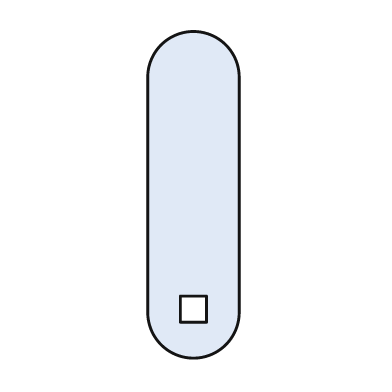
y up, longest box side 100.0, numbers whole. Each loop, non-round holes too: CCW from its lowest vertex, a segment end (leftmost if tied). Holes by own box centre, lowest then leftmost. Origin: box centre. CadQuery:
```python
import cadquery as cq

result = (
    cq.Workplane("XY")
    .moveTo(-14.0, -36.0)
    .threePointArc((0.0, -50.0), (14.0, -36.0))
    .lineTo(14.0, 36.0)
    .threePointArc((0.0, 50.0), (-14.0, 36.0))
    .close()
    .moveTo(-4.0, -39.0)
    .lineTo(4.0, -39.0)
    .lineTo(4.0, -31.0)
    .lineTo(-4.0, -31.0)
    .close()
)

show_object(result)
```